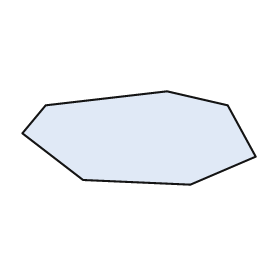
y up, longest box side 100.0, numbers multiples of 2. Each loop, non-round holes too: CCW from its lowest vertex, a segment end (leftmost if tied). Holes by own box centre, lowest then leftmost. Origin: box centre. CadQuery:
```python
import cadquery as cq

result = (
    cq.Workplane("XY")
    .moveTo(22.0, -20.0)
    .lineTo(50.0, -8.0)
    .lineTo(38.0, 14.0)
    .lineTo(12.0, 20.0)
    .lineTo(-40.0, 14.0)
    .lineTo(-50.0, 2.0)
    .lineTo(-24.0, -18.0)
    .close()
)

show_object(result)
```